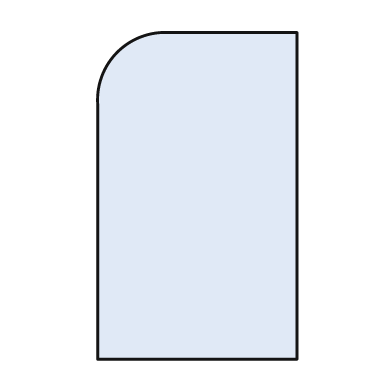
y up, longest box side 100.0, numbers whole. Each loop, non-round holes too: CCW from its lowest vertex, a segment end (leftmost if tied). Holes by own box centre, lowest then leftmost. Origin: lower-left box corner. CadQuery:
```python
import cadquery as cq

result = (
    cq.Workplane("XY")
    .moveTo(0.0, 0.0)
    .lineTo(61.0, 0.0)
    .lineTo(61.0, 100.0)
    .lineTo(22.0, 100.0)
    .threePointArc((6.0, 94.0), (0.0, 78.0))
    .close()
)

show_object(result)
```